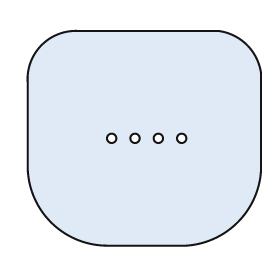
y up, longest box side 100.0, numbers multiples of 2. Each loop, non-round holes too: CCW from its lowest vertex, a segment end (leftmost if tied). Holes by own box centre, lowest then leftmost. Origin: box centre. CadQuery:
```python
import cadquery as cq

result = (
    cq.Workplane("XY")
    .moveTo(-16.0, -46.0)
    .lineTo(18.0, -46.0)
    .threePointArc((40.0, -36.0), (50.0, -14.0))
    .lineTo(50.0, 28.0)
    .threePointArc((44.0, 40.0), (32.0, 46.0))
    .lineTo(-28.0, 46.0)
    .threePointArc((-44.0, 40.0), (-50.0, 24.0))
    .lineTo(-50.0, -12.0)
    .threePointArc((-40.0, -36.0), (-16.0, -46.0))
    .close()
    .moveTo(-14.0, 0.0)
    .circle(2.0)
    .moveTo(-4.0, 0.0)
    .circle(2.0)
    .moveTo(6.0, 0.0)
    .circle(2.0)
    .moveTo(16.0, 0.0)
    .circle(2.0)
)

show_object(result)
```